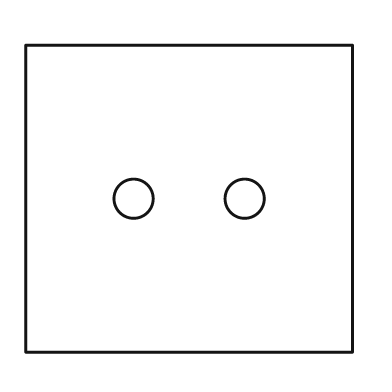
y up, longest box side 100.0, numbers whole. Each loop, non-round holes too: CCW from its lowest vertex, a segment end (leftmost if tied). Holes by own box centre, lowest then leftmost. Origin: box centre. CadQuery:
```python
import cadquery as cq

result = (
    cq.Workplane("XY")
    .moveTo(-50.0, -47.0)
    .lineTo(50.0, -47.0)
    .lineTo(50.0, 47.0)
    .lineTo(-50.0, 47.0)
    .close()
    .moveTo(-17.0, 0.0)
    .circle(6.0)
    .moveTo(17.0, 0.0)
    .circle(6.0)
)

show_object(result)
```